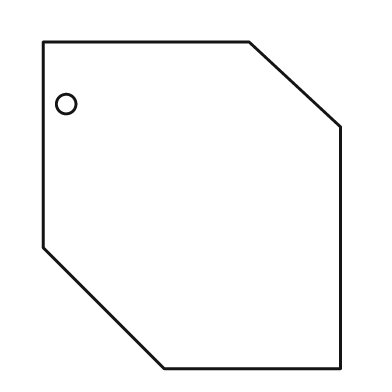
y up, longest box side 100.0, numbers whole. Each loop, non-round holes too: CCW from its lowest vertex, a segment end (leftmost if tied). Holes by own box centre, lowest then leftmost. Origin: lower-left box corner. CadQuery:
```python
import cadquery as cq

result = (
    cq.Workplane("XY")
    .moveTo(37.0, 0.0)
    .lineTo(91.0, 0.0)
    .lineTo(91.0, 74.0)
    .lineTo(63.0, 100.0)
    .lineTo(0.0, 100.0)
    .lineTo(0.0, 37.0)
    .close()
    .moveTo(7.0, 81.0)
    .circle(3.0)
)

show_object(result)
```